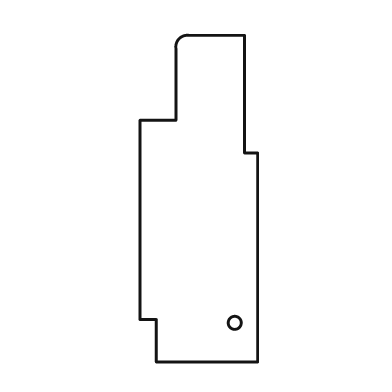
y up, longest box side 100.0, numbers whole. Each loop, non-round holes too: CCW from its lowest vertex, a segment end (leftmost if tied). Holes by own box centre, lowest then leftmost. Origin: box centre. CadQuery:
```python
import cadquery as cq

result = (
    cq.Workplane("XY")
    .moveTo(-13.0, -50.0)
    .lineTo(18.0, -50.0)
    .lineTo(18.0, 14.0)
    .lineTo(14.0, 14.0)
    .lineTo(14.0, 50.0)
    .lineTo(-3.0, 50.0)
    .threePointArc((-6.0, 49.0), (-7.0, 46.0))
    .lineTo(-7.0, 24.0)
    .lineTo(-18.0, 24.0)
    .lineTo(-18.0, -37.0)
    .lineTo(-13.0, -37.0)
    .close()
    .moveTo(11.0, -38.0)
    .circle(2.0)
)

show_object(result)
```